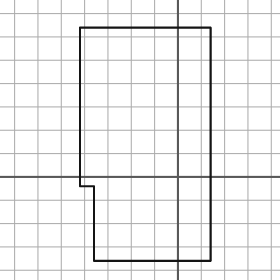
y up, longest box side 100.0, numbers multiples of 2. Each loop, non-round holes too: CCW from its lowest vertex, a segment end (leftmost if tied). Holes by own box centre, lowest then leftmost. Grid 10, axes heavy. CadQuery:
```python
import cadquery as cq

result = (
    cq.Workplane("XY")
    .moveTo(-36.0, -36.0)
    .lineTo(14.0, -36.0)
    .lineTo(14.0, 64.0)
    .lineTo(-42.0, 64.0)
    .lineTo(-42.0, -4.0)
    .lineTo(-36.0, -4.0)
    .close()
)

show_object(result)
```